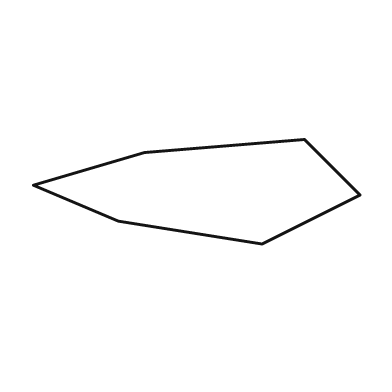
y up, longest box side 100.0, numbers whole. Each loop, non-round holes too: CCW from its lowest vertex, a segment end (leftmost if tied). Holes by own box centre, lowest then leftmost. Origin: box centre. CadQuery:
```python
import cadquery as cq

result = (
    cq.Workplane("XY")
    .moveTo(20.0, -16.0)
    .lineTo(50.0, -1.0)
    .lineTo(33.0, 16.0)
    .lineTo(-16.0, 12.0)
    .lineTo(-50.0, 2.0)
    .lineTo(-24.0, -9.0)
    .close()
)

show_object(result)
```